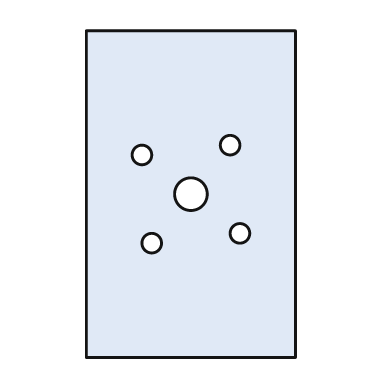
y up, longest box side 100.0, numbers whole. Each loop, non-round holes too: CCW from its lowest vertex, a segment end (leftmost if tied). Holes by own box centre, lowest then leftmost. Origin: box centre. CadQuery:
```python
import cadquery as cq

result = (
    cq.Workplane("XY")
    .moveTo(-32.0, -50.0)
    .lineTo(32.0, -50.0)
    .lineTo(32.0, 50.0)
    .lineTo(-32.0, 50.0)
    .close()
    .moveTo(-12.0, -15.0)
    .circle(3.0)
    .moveTo(15.0, -12.0)
    .circle(3.0)
    .moveTo(0.0, 0.0)
    .circle(5.0)
    .moveTo(-15.0, 12.0)
    .circle(3.0)
    .moveTo(12.0, 15.0)
    .circle(3.0)
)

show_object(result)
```